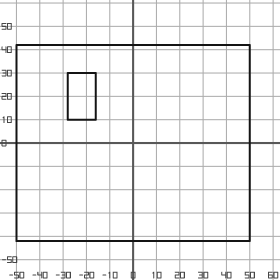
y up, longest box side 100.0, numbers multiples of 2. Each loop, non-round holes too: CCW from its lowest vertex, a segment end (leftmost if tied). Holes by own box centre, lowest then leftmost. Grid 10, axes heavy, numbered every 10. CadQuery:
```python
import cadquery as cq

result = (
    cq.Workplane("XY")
    .moveTo(-50.0, -42.0)
    .lineTo(50.0, -42.0)
    .lineTo(50.0, 42.0)
    .lineTo(-50.0, 42.0)
    .close()
    .moveTo(-28.0, 10.0)
    .lineTo(-16.0, 10.0)
    .lineTo(-16.0, 30.0)
    .lineTo(-28.0, 30.0)
    .close()
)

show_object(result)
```